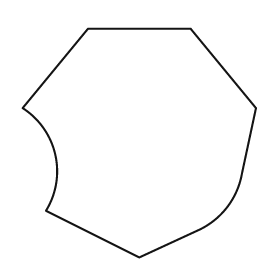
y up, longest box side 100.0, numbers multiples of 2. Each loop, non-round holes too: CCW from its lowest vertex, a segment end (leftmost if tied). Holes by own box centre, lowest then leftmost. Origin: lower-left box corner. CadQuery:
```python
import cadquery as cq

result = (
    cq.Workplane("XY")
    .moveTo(50.0, 0.0)
    .lineTo(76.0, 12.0)
    .threePointArc((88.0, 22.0), (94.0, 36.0))
    .lineTo(100.0, 64.0)
    .lineTo(72.0, 98.0)
    .lineTo(28.0, 98.0)
    .lineTo(0.0, 64.0)
    .threePointArc((14.0, 44.0), (10.0, 20.0))
    .close()
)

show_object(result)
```